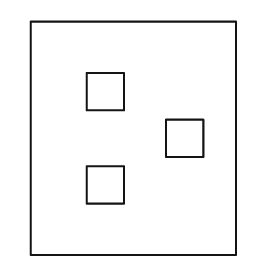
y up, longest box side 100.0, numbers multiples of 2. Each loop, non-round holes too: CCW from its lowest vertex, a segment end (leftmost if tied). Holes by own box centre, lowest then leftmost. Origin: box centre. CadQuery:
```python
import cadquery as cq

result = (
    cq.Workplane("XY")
    .moveTo(-44.0, -50.0)
    .lineTo(44.0, -50.0)
    .lineTo(44.0, 50.0)
    .lineTo(-44.0, 50.0)
    .close()
    .moveTo(-20.0, -28.0)
    .lineTo(-4.0, -28.0)
    .lineTo(-4.0, -12.0)
    .lineTo(-20.0, -12.0)
    .close()
    .moveTo(14.0, -8.0)
    .lineTo(30.0, -8.0)
    .lineTo(30.0, 8.0)
    .lineTo(14.0, 8.0)
    .close()
    .moveTo(-20.0, 12.0)
    .lineTo(-4.0, 12.0)
    .lineTo(-4.0, 28.0)
    .lineTo(-20.0, 28.0)
    .close()
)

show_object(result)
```